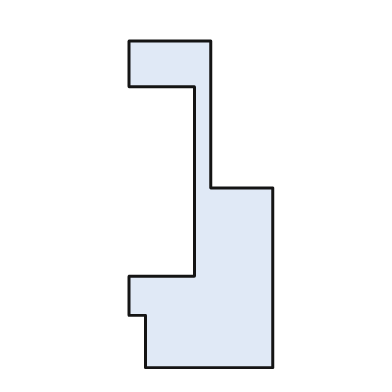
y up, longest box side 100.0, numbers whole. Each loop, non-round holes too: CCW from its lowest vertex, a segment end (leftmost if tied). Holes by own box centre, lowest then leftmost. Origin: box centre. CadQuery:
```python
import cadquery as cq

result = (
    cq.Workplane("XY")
    .moveTo(-17.0, -50.0)
    .lineTo(22.0, -50.0)
    .lineTo(22.0, 5.0)
    .lineTo(3.0, 5.0)
    .lineTo(3.0, 50.0)
    .lineTo(-22.0, 50.0)
    .lineTo(-22.0, 36.0)
    .lineTo(-2.0, 36.0)
    .lineTo(-2.0, -22.0)
    .lineTo(-22.0, -22.0)
    .lineTo(-22.0, -34.0)
    .lineTo(-17.0, -34.0)
    .close()
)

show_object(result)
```